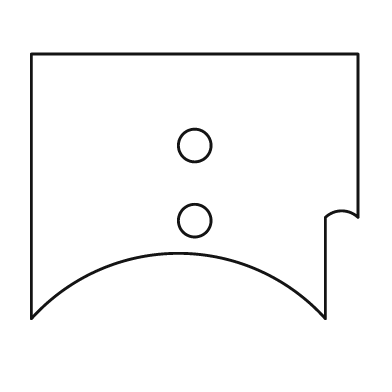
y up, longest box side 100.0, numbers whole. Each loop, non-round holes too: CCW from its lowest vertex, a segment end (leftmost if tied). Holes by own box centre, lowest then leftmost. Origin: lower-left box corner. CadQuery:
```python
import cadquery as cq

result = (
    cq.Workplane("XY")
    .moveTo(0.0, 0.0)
    .threePointArc((45.0, 20.0), (90.0, 0.0))
    .lineTo(90.0, 31.0)
    .threePointArc((95.0, 33.0), (100.0, 31.0))
    .lineTo(100.0, 81.0)
    .lineTo(0.0, 81.0)
    .close()
    .moveTo(50.0, 30.0)
    .circle(5.0)
    .moveTo(50.0, 53.0)
    .circle(5.0)
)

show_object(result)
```